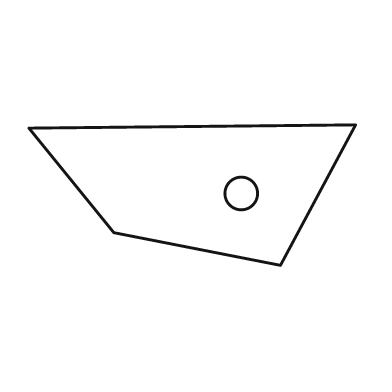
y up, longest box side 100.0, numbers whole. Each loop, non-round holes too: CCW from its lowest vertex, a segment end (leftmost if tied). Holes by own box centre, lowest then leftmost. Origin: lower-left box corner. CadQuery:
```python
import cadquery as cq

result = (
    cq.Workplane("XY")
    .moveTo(77.0, 0.0)
    .lineTo(100.0, 43.0)
    .lineTo(0.0, 42.0)
    .lineTo(26.0, 10.0)
    .close()
    .moveTo(65.0, 22.0)
    .circle(5.0)
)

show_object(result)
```